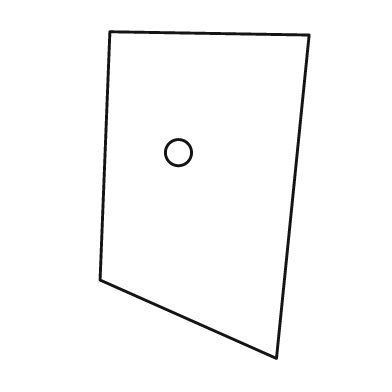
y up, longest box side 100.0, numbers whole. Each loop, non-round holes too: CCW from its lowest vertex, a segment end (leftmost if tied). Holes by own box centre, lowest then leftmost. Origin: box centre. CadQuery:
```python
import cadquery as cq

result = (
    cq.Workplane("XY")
    .moveTo(22.0, -50.0)
    .lineTo(32.0, 49.0)
    .lineTo(-29.0, 50.0)
    .lineTo(-32.0, -26.0)
    .close()
    .moveTo(-8.0, 13.0)
    .circle(4.0)
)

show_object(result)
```